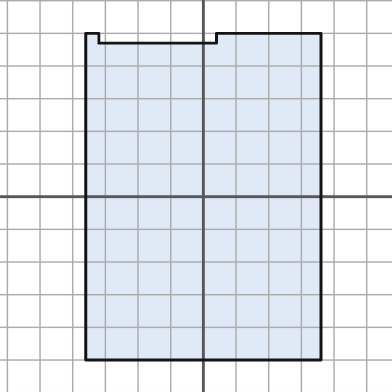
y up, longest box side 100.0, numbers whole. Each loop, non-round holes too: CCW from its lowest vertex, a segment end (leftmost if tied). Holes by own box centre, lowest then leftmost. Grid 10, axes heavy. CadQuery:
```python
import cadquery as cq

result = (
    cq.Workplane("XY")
    .moveTo(-36.0, -50.0)
    .lineTo(36.0, -50.0)
    .lineTo(36.0, 50.0)
    .lineTo(4.0, 50.0)
    .lineTo(4.0, 47.0)
    .lineTo(-32.0, 47.0)
    .lineTo(-32.0, 50.0)
    .lineTo(-36.0, 50.0)
    .close()
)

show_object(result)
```